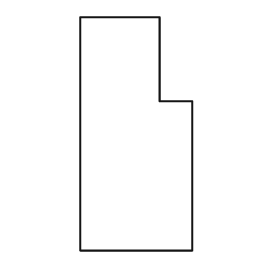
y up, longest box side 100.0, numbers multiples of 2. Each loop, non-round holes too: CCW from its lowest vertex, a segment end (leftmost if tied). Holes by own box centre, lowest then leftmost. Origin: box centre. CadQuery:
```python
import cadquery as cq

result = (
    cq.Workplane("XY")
    .moveTo(-24.0, -50.0)
    .lineTo(24.0, -50.0)
    .lineTo(24.0, 14.0)
    .lineTo(10.0, 14.0)
    .lineTo(10.0, 50.0)
    .lineTo(-24.0, 50.0)
    .close()
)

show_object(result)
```